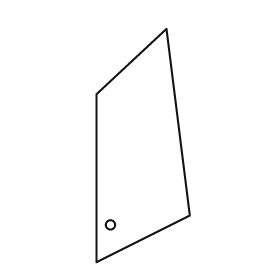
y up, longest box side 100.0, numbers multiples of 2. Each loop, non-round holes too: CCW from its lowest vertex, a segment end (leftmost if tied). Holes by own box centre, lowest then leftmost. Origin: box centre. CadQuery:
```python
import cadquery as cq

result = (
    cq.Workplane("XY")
    .moveTo(-20.0, -50.0)
    .lineTo(20.0, -30.0)
    .lineTo(10.0, 50.0)
    .lineTo(-20.0, 22.0)
    .close()
    .moveTo(-14.0, -34.0)
    .circle(2.0)
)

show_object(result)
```